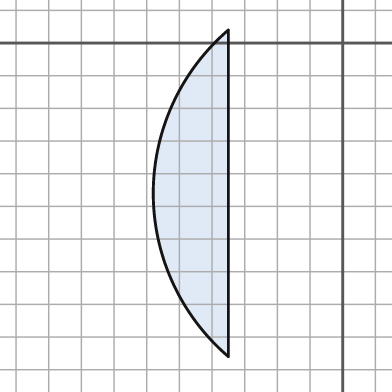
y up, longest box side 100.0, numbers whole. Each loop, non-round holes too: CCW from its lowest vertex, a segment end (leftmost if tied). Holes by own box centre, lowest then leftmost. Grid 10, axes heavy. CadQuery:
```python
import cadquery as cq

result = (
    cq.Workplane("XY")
    .moveTo(-35.0, -96.0)
    .lineTo(-35.0, 4.0)
    .threePointArc((-58.0, -46.0), (-35.0, -96.0))
    .close()
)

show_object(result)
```